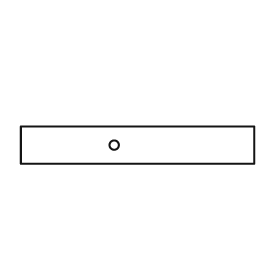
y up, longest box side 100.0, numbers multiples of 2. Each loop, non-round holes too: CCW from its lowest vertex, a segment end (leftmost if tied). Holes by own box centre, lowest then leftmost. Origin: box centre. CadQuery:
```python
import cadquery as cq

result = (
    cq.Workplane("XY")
    .moveTo(-50.0, -8.0)
    .lineTo(50.0, -8.0)
    .lineTo(50.0, 8.0)
    .lineTo(-50.0, 8.0)
    .close()
    .moveTo(-10.0, 0.0)
    .circle(2.0)
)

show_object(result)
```